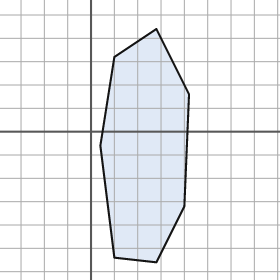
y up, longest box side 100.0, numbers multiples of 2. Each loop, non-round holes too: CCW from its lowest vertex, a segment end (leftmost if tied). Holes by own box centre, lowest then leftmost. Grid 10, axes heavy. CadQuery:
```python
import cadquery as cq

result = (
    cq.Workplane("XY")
    .moveTo(28.0, -56.0)
    .lineTo(40.0, -32.0)
    .lineTo(42.0, 16.0)
    .lineTo(28.0, 44.0)
    .lineTo(10.0, 32.0)
    .lineTo(4.0, -6.0)
    .lineTo(10.0, -54.0)
    .close()
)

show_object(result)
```